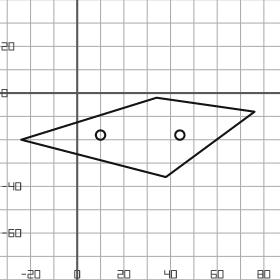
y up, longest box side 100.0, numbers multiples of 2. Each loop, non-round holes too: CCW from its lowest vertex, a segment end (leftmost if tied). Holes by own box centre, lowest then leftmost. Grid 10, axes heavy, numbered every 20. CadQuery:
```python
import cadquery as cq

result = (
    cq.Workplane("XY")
    .moveTo(38.0, -36.0)
    .lineTo(76.0, -8.0)
    .lineTo(34.0, -2.0)
    .lineTo(-24.0, -20.0)
    .close()
    .moveTo(10.0, -18.0)
    .circle(2.0)
    .moveTo(44.0, -18.0)
    .circle(2.0)
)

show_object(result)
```